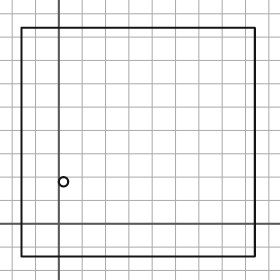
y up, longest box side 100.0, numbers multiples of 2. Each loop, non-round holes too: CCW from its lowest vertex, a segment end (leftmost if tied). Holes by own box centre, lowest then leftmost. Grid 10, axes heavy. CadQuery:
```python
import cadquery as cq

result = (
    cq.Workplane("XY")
    .moveTo(-16.0, -14.0)
    .lineTo(84.0, -14.0)
    .lineTo(84.0, 84.0)
    .lineTo(-16.0, 84.0)
    .close()
    .moveTo(2.0, 18.0)
    .circle(2.0)
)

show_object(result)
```